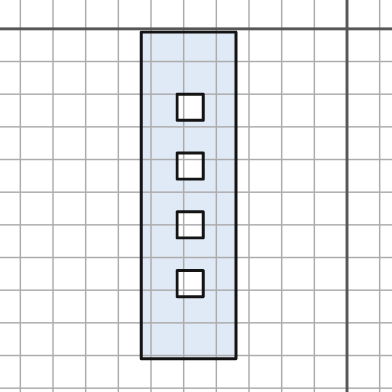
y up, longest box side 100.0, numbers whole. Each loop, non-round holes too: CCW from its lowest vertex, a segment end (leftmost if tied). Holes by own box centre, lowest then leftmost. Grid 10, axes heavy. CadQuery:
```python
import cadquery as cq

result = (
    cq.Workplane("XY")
    .moveTo(-63.0, -101.0)
    .lineTo(-34.0, -101.0)
    .lineTo(-34.0, -1.0)
    .lineTo(-63.0, -1.0)
    .close()
    .moveTo(-52.0, -82.0)
    .lineTo(-44.0, -82.0)
    .lineTo(-44.0, -74.0)
    .lineTo(-52.0, -74.0)
    .close()
    .moveTo(-52.0, -64.0)
    .lineTo(-44.0, -64.0)
    .lineTo(-44.0, -56.0)
    .lineTo(-52.0, -56.0)
    .close()
    .moveTo(-52.0, -46.0)
    .lineTo(-44.0, -46.0)
    .lineTo(-44.0, -38.0)
    .lineTo(-52.0, -38.0)
    .close()
    .moveTo(-52.0, -28.0)
    .lineTo(-44.0, -28.0)
    .lineTo(-44.0, -20.0)
    .lineTo(-52.0, -20.0)
    .close()
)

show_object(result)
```